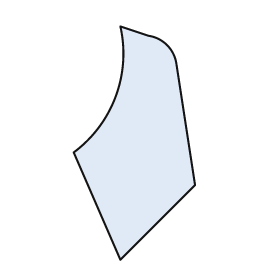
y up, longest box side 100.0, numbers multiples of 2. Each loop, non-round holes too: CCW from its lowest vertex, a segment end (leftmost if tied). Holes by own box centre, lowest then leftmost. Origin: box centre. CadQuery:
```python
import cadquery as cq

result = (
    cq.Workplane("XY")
    .moveTo(-6.0, -50.0)
    .lineTo(26.0, -18.0)
    .lineTo(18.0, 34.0)
    .threePointArc((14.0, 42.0), (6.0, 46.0))
    .lineTo(-6.0, 50.0)
    .threePointArc((-8.0, 20.0), (-26.0, -4.0))
    .close()
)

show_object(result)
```